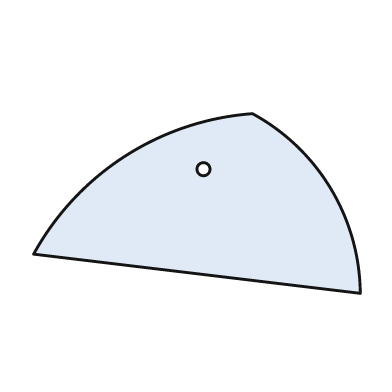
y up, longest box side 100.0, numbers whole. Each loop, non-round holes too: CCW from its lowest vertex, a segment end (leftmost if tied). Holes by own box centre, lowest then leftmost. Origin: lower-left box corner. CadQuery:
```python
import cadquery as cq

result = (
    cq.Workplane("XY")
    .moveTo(100.0, 0.0)
    .threePointArc((91.0, 32.0), (67.0, 55.0))
    .threePointArc((28.0, 42.0), (0.0, 12.0))
    .close()
    .moveTo(52.0, 38.0)
    .circle(2.0)
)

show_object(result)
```